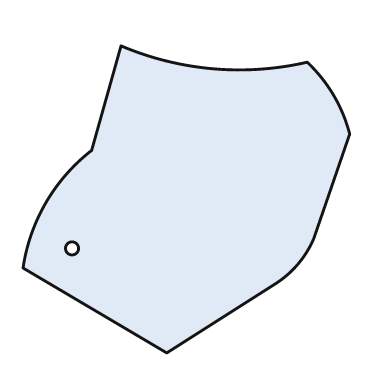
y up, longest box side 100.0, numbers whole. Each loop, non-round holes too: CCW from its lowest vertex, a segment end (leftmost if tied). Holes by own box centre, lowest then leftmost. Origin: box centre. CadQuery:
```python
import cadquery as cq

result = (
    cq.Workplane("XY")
    .moveTo(-6.0, -47.0)
    .lineTo(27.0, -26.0)
    .threePointArc((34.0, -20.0), (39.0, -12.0))
    .lineTo(50.0, 20.0)
    .threePointArc((45.0, 32.0), (37.0, 42.0))
    .threePointArc((8.0, 40.0), (-20.0, 47.0))
    .lineTo(-29.0, 15.0)
    .threePointArc((-43.0, -1.0), (-50.0, -21.0))
    .close()
    .moveTo(-35.0, -15.0)
    .circle(2.0)
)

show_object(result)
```